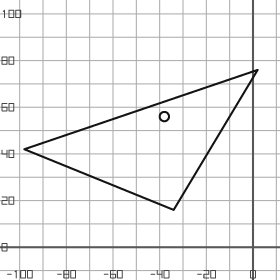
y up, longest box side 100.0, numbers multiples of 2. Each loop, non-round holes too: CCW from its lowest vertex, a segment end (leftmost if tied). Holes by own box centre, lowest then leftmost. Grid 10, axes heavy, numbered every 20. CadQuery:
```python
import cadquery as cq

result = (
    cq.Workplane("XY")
    .moveTo(-34.0, 16.0)
    .lineTo(2.0, 76.0)
    .lineTo(-98.0, 42.0)
    .close()
    .moveTo(-38.0, 56.0)
    .circle(2.0)
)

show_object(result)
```